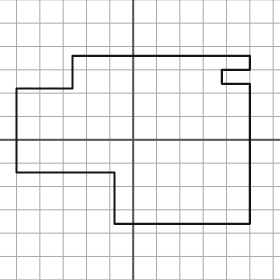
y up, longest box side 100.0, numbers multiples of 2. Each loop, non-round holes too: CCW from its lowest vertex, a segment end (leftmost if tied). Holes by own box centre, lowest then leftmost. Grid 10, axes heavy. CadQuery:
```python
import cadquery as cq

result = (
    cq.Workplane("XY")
    .moveTo(-8.0, -36.0)
    .lineTo(50.0, -36.0)
    .lineTo(50.0, 24.0)
    .lineTo(38.0, 24.0)
    .lineTo(38.0, 30.0)
    .lineTo(50.0, 30.0)
    .lineTo(50.0, 36.0)
    .lineTo(-26.0, 36.0)
    .lineTo(-26.0, 22.0)
    .lineTo(-50.0, 22.0)
    .lineTo(-50.0, -14.0)
    .lineTo(-8.0, -14.0)
    .close()
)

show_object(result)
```